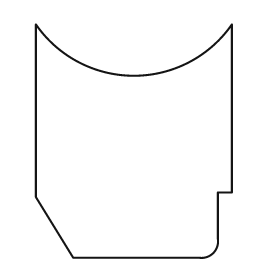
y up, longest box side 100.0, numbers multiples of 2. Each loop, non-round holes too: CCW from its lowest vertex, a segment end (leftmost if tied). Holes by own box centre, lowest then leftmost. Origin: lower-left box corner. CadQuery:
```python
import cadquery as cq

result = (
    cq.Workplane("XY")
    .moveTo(16.0, 0.0)
    .lineTo(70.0, 0.0)
    .threePointArc((76.0, 2.0), (78.0, 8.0))
    .lineTo(78.0, 28.0)
    .lineTo(84.0, 28.0)
    .lineTo(84.0, 100.0)
    .threePointArc((42.0, 78.0), (0.0, 100.0))
    .lineTo(0.0, 26.0)
    .close()
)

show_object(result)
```